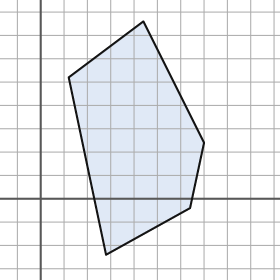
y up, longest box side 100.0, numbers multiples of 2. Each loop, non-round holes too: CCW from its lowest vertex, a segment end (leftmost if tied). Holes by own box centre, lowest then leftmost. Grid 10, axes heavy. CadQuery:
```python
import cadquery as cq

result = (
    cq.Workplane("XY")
    .moveTo(28.0, -24.0)
    .lineTo(64.0, -4.0)
    .lineTo(70.0, 24.0)
    .lineTo(44.0, 76.0)
    .lineTo(12.0, 52.0)
    .close()
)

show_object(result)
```